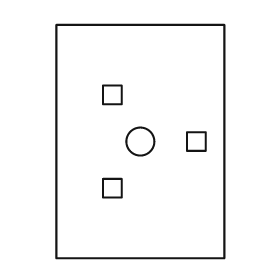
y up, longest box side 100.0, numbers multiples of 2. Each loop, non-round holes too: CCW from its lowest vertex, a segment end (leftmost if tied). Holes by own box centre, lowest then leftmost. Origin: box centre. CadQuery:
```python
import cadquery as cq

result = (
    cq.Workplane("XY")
    .moveTo(-36.0, -50.0)
    .lineTo(36.0, -50.0)
    .lineTo(36.0, 50.0)
    .lineTo(-36.0, 50.0)
    .close()
    .moveTo(-16.0, -24.0)
    .lineTo(-8.0, -24.0)
    .lineTo(-8.0, -16.0)
    .lineTo(-16.0, -16.0)
    .close()
    .moveTo(0.0, 0.0)
    .circle(6.0)
    .moveTo(20.0, -4.0)
    .lineTo(28.0, -4.0)
    .lineTo(28.0, 4.0)
    .lineTo(20.0, 4.0)
    .close()
    .moveTo(-16.0, 16.0)
    .lineTo(-8.0, 16.0)
    .lineTo(-8.0, 24.0)
    .lineTo(-16.0, 24.0)
    .close()
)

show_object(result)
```